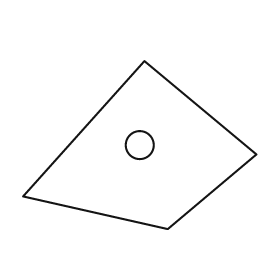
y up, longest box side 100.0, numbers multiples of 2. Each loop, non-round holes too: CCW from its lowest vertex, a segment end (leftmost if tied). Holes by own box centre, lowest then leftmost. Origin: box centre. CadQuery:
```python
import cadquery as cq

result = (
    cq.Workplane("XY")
    .moveTo(12.0, -36.0)
    .lineTo(50.0, -4.0)
    .lineTo(2.0, 36.0)
    .lineTo(-50.0, -22.0)
    .close()
    .moveTo(0.0, 0.0)
    .circle(6.0)
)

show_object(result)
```